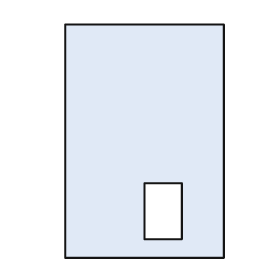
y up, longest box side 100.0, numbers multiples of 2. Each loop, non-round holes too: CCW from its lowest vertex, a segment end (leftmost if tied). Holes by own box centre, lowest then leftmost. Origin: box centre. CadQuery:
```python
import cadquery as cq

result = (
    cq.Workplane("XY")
    .moveTo(-34.0, -50.0)
    .lineTo(34.0, -50.0)
    .lineTo(34.0, 50.0)
    .lineTo(-34.0, 50.0)
    .close()
    .moveTo(0.0, -42.0)
    .lineTo(16.0, -42.0)
    .lineTo(16.0, -18.0)
    .lineTo(0.0, -18.0)
    .close()
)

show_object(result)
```